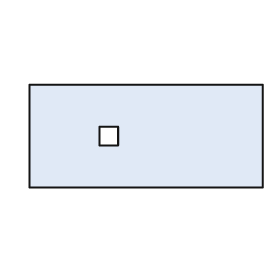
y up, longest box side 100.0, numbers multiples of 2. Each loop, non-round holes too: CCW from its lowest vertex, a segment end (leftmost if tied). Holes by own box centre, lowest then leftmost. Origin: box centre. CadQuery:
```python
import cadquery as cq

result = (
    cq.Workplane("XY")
    .moveTo(-50.0, -22.0)
    .lineTo(50.0, -22.0)
    .lineTo(50.0, 22.0)
    .lineTo(-50.0, 22.0)
    .close()
    .moveTo(-20.0, -4.0)
    .lineTo(-12.0, -4.0)
    .lineTo(-12.0, 4.0)
    .lineTo(-20.0, 4.0)
    .close()
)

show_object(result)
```